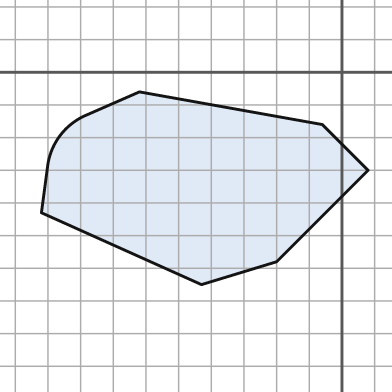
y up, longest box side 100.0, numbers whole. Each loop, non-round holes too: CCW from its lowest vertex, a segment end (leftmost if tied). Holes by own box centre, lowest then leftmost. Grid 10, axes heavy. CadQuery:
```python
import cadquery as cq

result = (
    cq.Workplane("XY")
    .moveTo(-43.0, -65.0)
    .lineTo(-20.0, -58.0)
    .lineTo(8.0, -30.0)
    .lineTo(-6.0, -16.0)
    .lineTo(-62.0, -6.0)
    .lineTo(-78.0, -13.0)
    .threePointArc((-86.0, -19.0), (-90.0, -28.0))
    .lineTo(-92.0, -43.0)
    .close()
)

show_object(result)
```